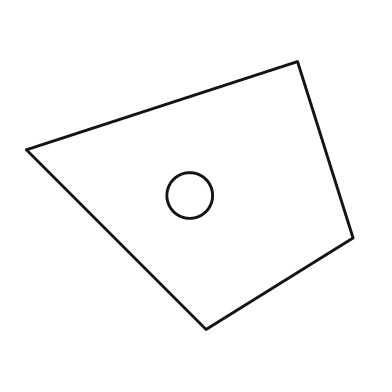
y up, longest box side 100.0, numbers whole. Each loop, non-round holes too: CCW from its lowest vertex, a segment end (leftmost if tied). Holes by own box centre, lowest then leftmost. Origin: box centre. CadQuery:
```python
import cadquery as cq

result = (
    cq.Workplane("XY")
    .moveTo(5.0, -41.0)
    .lineTo(50.0, -13.0)
    .lineTo(33.0, 41.0)
    .lineTo(-50.0, 14.0)
    .close()
    .moveTo(0.0, 0.0)
    .circle(7.0)
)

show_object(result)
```